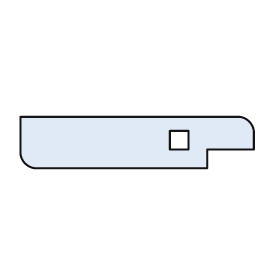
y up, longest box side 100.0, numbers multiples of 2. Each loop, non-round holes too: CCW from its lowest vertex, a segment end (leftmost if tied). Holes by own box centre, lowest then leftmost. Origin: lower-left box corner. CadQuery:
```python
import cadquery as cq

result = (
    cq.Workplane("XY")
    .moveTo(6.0, 0.0)
    .lineTo(80.0, 0.0)
    .lineTo(80.0, 8.0)
    .lineTo(100.0, 8.0)
    .lineTo(100.0, 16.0)
    .threePointArc((98.0, 20.0), (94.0, 22.0))
    .lineTo(0.0, 22.0)
    .lineTo(0.0, 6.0)
    .threePointArc((2.0, 2.0), (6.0, 0.0))
    .close()
    .moveTo(64.0, 8.0)
    .lineTo(72.0, 8.0)
    .lineTo(72.0, 16.0)
    .lineTo(64.0, 16.0)
    .close()
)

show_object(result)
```